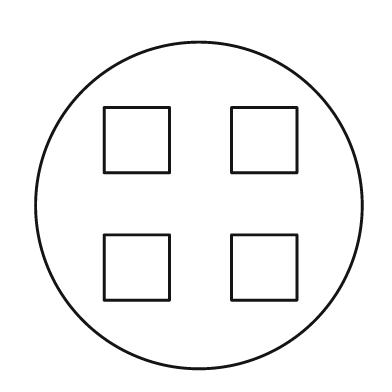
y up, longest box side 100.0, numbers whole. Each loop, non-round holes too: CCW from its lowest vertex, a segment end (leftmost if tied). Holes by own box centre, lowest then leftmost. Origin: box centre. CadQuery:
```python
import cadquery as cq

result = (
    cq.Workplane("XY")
    .moveTo(0.0, 0.0)
    .circle(50.0)
    .moveTo(-29.0, -29.0)
    .lineTo(-9.0, -29.0)
    .lineTo(-9.0, -9.0)
    .lineTo(-29.0, -9.0)
    .close()
    .moveTo(10.0, -29.0)
    .lineTo(30.0, -29.0)
    .lineTo(30.0, -9.0)
    .lineTo(10.0, -9.0)
    .close()
    .moveTo(-29.0, 10.0)
    .lineTo(-9.0, 10.0)
    .lineTo(-9.0, 30.0)
    .lineTo(-29.0, 30.0)
    .close()
    .moveTo(10.0, 10.0)
    .lineTo(30.0, 10.0)
    .lineTo(30.0, 30.0)
    .lineTo(10.0, 30.0)
    .close()
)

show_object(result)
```